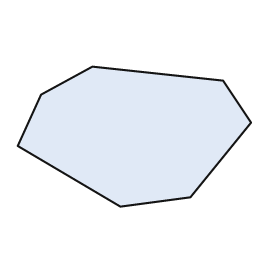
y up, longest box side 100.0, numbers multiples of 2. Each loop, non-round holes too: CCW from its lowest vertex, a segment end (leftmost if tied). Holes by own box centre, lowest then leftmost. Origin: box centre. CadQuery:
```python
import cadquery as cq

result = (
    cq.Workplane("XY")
    .moveTo(-6.0, -30.0)
    .lineTo(24.0, -26.0)
    .lineTo(50.0, 6.0)
    .lineTo(38.0, 24.0)
    .lineTo(-18.0, 30.0)
    .lineTo(-40.0, 18.0)
    .lineTo(-50.0, -4.0)
    .close()
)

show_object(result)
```